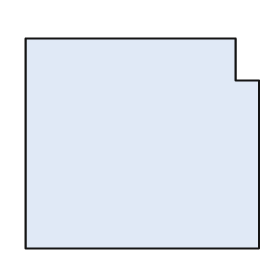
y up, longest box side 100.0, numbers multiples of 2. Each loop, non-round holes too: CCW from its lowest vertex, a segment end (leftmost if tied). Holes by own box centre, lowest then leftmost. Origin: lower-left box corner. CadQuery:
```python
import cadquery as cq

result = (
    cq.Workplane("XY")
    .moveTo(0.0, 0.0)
    .lineTo(100.0, 0.0)
    .lineTo(100.0, 72.0)
    .lineTo(90.0, 72.0)
    .lineTo(90.0, 90.0)
    .lineTo(0.0, 90.0)
    .close()
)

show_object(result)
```